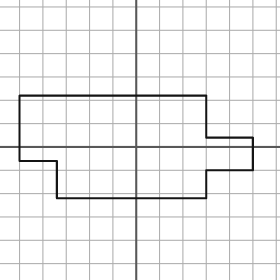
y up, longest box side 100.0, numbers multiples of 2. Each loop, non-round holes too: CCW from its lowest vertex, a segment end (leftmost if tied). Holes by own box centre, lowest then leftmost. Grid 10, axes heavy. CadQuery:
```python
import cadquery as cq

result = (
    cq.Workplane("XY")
    .moveTo(-34.0, -22.0)
    .lineTo(30.0, -22.0)
    .lineTo(30.0, -10.0)
    .lineTo(50.0, -10.0)
    .lineTo(50.0, 4.0)
    .lineTo(30.0, 4.0)
    .lineTo(30.0, 22.0)
    .lineTo(-50.0, 22.0)
    .lineTo(-50.0, -6.0)
    .lineTo(-34.0, -6.0)
    .close()
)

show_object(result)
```